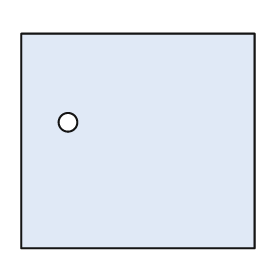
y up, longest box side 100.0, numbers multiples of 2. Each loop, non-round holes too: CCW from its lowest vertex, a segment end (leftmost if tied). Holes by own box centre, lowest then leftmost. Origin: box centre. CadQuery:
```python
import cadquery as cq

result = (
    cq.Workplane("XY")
    .moveTo(-50.0, -46.0)
    .lineTo(50.0, -46.0)
    .lineTo(50.0, 46.0)
    .lineTo(-50.0, 46.0)
    .close()
    .moveTo(-30.0, 8.0)
    .circle(4.0)
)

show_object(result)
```